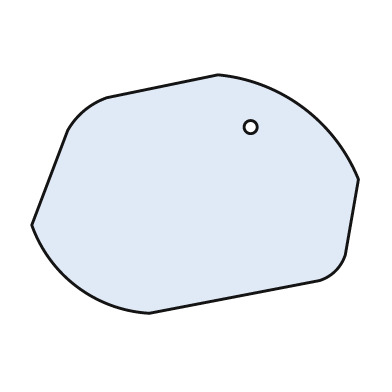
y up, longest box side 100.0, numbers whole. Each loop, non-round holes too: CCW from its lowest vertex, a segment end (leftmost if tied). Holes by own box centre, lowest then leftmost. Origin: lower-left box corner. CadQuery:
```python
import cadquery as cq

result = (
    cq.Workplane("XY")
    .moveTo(36.0, 0.0)
    .lineTo(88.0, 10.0)
    .threePointArc((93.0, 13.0), (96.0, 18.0))
    .lineTo(100.0, 41.0)
    .threePointArc((83.0, 63.0), (57.0, 73.0))
    .lineTo(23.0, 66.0)
    .threePointArc((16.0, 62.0), (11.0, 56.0))
    .lineTo(0.0, 27.0)
    .threePointArc((14.0, 8.0), (36.0, 0.0))
    .close()
    .moveTo(67.0, 57.0)
    .circle(2.0)
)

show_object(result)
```